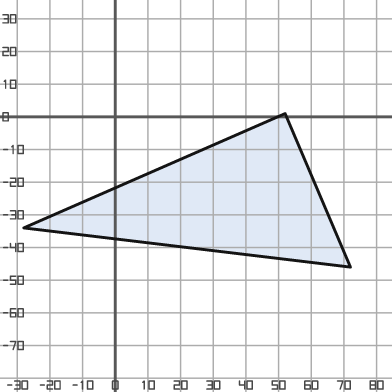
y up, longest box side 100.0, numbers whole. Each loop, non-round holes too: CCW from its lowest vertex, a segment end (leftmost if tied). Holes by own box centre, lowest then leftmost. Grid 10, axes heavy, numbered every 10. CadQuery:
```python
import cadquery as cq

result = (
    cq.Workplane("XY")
    .moveTo(72.0, -46.0)
    .lineTo(52.0, 1.0)
    .lineTo(-28.0, -34.0)
    .close()
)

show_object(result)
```